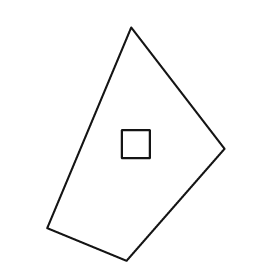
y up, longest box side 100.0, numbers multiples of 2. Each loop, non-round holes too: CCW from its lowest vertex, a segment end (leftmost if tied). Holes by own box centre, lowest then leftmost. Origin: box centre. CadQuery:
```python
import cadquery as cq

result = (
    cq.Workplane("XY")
    .moveTo(-4.0, -50.0)
    .lineTo(38.0, -2.0)
    .lineTo(-2.0, 50.0)
    .lineTo(-38.0, -36.0)
    .close()
    .moveTo(-6.0, -6.0)
    .lineTo(6.0, -6.0)
    .lineTo(6.0, 6.0)
    .lineTo(-6.0, 6.0)
    .close()
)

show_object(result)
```